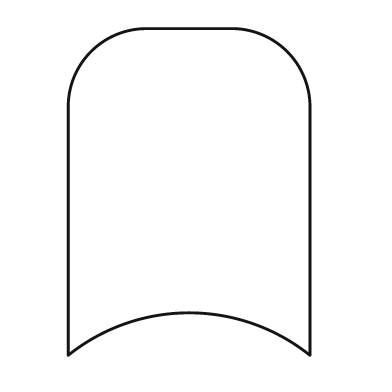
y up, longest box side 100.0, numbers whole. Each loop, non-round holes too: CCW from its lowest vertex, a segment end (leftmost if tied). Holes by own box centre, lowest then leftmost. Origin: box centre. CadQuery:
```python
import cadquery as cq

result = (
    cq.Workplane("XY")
    .moveTo(-37.0, -50.0)
    .threePointArc((0.0, -37.0), (37.0, -50.0))
    .lineTo(37.0, 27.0)
    .threePointArc((30.0, 43.0), (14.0, 50.0))
    .lineTo(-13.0, 50.0)
    .threePointArc((-30.0, 43.0), (-37.0, 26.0))
    .close()
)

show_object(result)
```